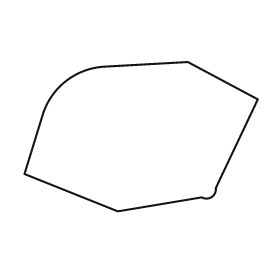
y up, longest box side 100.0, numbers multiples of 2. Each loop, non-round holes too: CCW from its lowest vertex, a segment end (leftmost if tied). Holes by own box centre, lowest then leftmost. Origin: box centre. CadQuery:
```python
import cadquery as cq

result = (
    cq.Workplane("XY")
    .moveTo(-10.0, -32.0)
    .lineTo(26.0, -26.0)
    .threePointArc((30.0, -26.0), (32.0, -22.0))
    .lineTo(50.0, 16.0)
    .lineTo(20.0, 32.0)
    .lineTo(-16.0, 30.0)
    .threePointArc((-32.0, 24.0), (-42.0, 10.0))
    .lineTo(-50.0, -16.0)
    .close()
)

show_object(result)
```